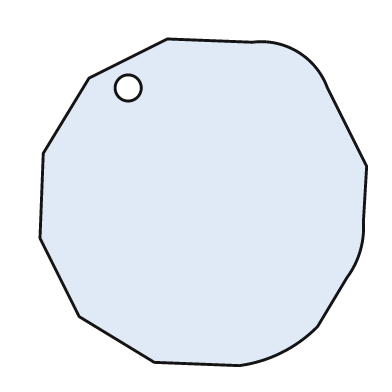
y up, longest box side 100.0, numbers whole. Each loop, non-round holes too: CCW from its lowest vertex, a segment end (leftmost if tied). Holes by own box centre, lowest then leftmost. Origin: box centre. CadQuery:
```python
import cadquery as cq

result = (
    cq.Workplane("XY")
    .moveTo(11.0, -50.0)
    .threePointArc((24.0, -46.0), (35.0, -38.0))
    .lineTo(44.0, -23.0)
    .threePointArc((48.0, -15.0), (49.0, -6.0))
    .lineTo(50.0, 11.0)
    .lineTo(38.0, 35.0)
    .threePointArc((29.0, 46.0), (15.0, 49.0))
    .lineTo(-11.0, 50.0)
    .lineTo(-35.0, 38.0)
    .lineTo(-49.0, 15.0)
    .lineTo(-50.0, -11.0)
    .lineTo(-38.0, -35.0)
    .lineTo(-15.0, -49.0)
    .close()
    .moveTo(-23.0, 35.0)
    .circle(4.0)
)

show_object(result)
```